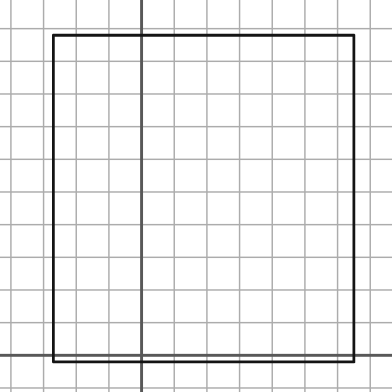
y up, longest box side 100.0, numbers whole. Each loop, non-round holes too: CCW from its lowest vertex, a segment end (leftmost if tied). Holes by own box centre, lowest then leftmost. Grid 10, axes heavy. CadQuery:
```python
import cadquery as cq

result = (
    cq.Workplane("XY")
    .moveTo(-27.0, -2.0)
    .lineTo(65.0, -2.0)
    .lineTo(65.0, 98.0)
    .lineTo(-27.0, 98.0)
    .close()
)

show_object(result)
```